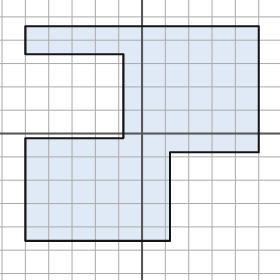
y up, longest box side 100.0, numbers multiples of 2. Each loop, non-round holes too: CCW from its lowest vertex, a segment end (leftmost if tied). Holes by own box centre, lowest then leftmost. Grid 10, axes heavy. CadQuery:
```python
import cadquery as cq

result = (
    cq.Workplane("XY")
    .moveTo(-50.0, -46.0)
    .lineTo(12.0, -46.0)
    .lineTo(12.0, -8.0)
    .lineTo(50.0, -8.0)
    .lineTo(50.0, 46.0)
    .lineTo(-50.0, 46.0)
    .lineTo(-50.0, 34.0)
    .lineTo(-8.0, 34.0)
    .lineTo(-8.0, -2.0)
    .lineTo(-50.0, -2.0)
    .close()
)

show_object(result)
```